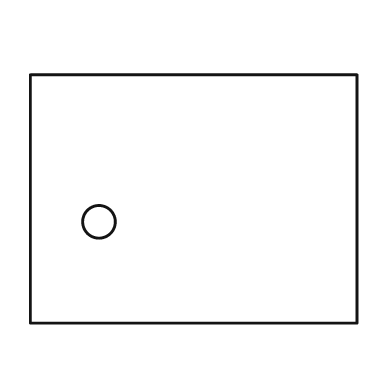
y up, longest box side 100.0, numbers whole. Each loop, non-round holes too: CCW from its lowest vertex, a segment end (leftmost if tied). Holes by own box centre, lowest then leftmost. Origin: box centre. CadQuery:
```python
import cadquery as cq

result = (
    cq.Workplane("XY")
    .moveTo(-50.0, -38.0)
    .lineTo(50.0, -38.0)
    .lineTo(50.0, 38.0)
    .lineTo(-50.0, 38.0)
    .close()
    .moveTo(-29.0, -7.0)
    .circle(5.0)
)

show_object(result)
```